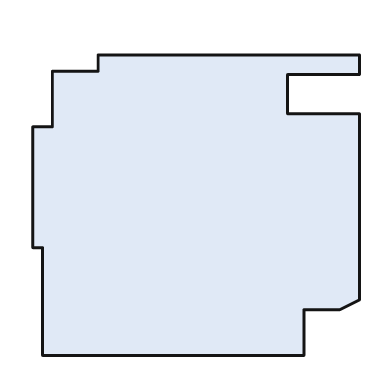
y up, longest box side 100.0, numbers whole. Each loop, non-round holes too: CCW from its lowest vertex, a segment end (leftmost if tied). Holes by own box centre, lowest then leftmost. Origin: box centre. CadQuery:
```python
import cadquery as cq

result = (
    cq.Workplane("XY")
    .moveTo(-47.0, -46.0)
    .lineTo(33.0, -46.0)
    .lineTo(33.0, -32.0)
    .lineTo(44.0, -32.0)
    .lineTo(50.0, -29.0)
    .lineTo(50.0, 28.0)
    .lineTo(28.0, 28.0)
    .lineTo(28.0, 40.0)
    .lineTo(50.0, 40.0)
    .lineTo(50.0, 46.0)
    .lineTo(-30.0, 46.0)
    .lineTo(-30.0, 41.0)
    .lineTo(-44.0, 41.0)
    .lineTo(-44.0, 24.0)
    .lineTo(-50.0, 24.0)
    .lineTo(-50.0, -13.0)
    .lineTo(-47.0, -13.0)
    .close()
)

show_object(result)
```